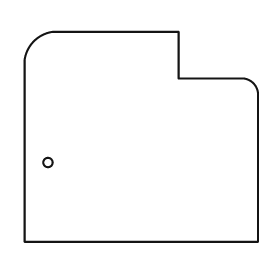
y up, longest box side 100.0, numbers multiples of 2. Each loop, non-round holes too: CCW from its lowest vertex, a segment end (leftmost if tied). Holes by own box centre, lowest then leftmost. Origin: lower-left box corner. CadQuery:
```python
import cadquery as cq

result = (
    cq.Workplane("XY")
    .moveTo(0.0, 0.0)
    .lineTo(100.0, 0.0)
    .lineTo(100.0, 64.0)
    .threePointArc((98.0, 68.0), (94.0, 70.0))
    .lineTo(66.0, 70.0)
    .lineTo(66.0, 90.0)
    .lineTo(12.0, 90.0)
    .threePointArc((4.0, 86.0), (0.0, 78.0))
    .close()
    .moveTo(10.0, 34.0)
    .circle(2.0)
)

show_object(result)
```